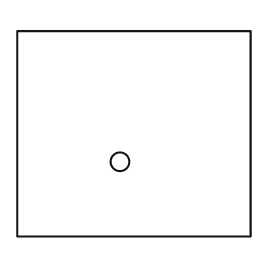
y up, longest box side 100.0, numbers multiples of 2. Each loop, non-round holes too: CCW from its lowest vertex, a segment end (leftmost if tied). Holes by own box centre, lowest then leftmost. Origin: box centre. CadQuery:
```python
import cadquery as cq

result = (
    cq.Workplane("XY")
    .moveTo(-50.0, -44.0)
    .lineTo(50.0, -44.0)
    .lineTo(50.0, 44.0)
    .lineTo(-50.0, 44.0)
    .close()
    .moveTo(-6.0, -12.0)
    .circle(4.0)
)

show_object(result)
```